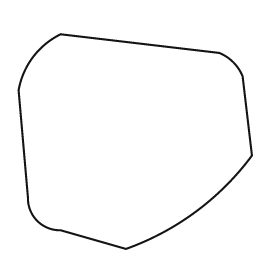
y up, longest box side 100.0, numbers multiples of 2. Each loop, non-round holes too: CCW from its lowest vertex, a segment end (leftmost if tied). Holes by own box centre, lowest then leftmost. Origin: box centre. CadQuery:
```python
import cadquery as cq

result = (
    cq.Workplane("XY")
    .moveTo(-4.0, -46.0)
    .threePointArc((26.0, -30.0), (50.0, -6.0))
    .lineTo(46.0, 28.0)
    .threePointArc((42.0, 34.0), (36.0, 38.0))
    .lineTo(-32.0, 46.0)
    .threePointArc((-44.0, 36.0), (-50.0, 22.0))
    .lineTo(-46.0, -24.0)
    .threePointArc((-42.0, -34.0), (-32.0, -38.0))
    .close()
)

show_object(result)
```